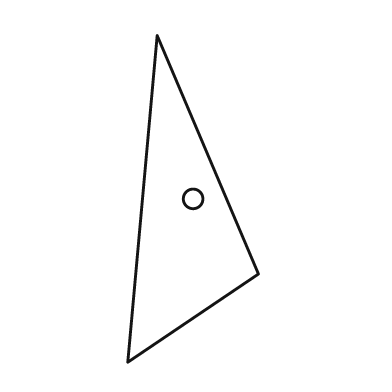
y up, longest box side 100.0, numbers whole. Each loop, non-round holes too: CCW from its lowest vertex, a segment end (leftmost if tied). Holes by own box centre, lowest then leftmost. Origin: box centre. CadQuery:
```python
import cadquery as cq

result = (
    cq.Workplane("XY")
    .moveTo(-20.0, -50.0)
    .lineTo(20.0, -23.0)
    .lineTo(-11.0, 50.0)
    .close()
    .moveTo(0.0, 0.0)
    .circle(3.0)
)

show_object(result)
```